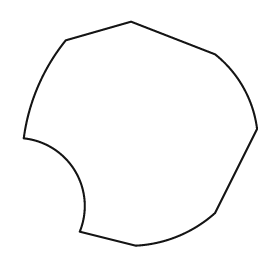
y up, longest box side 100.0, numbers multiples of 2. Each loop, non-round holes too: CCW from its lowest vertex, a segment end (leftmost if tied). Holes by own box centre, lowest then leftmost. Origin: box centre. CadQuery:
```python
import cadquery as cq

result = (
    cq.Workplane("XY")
    .moveTo(-2.0, -48.0)
    .threePointArc((16.0, -44.0), (32.0, -34.0))
    .lineTo(50.0, 2.0)
    .threePointArc((44.0, 20.0), (32.0, 34.0))
    .lineTo(-4.0, 48.0)
    .lineTo(-32.0, 40.0)
    .threePointArc((-44.0, 20.0), (-50.0, -2.0))
    .threePointArc((-28.0, -16.0), (-26.0, -42.0))
    .close()
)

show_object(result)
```